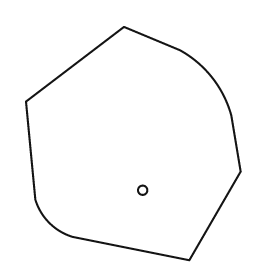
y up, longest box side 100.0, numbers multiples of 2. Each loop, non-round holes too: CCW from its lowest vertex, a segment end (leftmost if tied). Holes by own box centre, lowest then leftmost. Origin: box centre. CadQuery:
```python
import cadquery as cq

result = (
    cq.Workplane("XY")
    .moveTo(24.0, -50.0)
    .lineTo(46.0, -12.0)
    .lineTo(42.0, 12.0)
    .threePointArc((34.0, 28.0), (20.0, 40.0))
    .lineTo(-4.0, 50.0)
    .lineTo(-46.0, 18.0)
    .lineTo(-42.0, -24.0)
    .threePointArc((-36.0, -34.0), (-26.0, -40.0))
    .close()
    .moveTo(4.0, -20.0)
    .circle(2.0)
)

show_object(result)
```